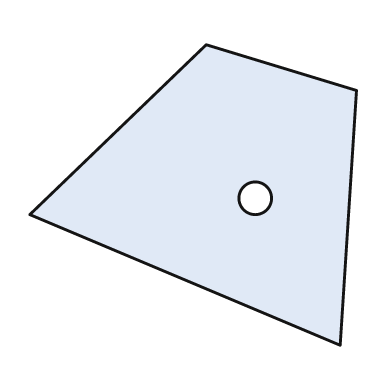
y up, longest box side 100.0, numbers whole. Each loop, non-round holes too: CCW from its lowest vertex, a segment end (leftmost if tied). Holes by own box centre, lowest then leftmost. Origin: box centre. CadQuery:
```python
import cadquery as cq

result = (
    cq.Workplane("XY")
    .moveTo(45.0, -46.0)
    .lineTo(50.0, 32.0)
    .lineTo(4.0, 46.0)
    .lineTo(-50.0, -6.0)
    .close()
    .moveTo(19.0, -1.0)
    .circle(5.0)
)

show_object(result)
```